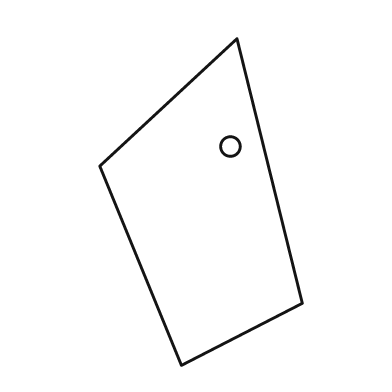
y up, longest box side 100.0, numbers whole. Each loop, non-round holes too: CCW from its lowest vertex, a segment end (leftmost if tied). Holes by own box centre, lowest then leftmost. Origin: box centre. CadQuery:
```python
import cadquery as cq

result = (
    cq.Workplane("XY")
    .moveTo(-6.0, -50.0)
    .lineTo(31.0, -31.0)
    .lineTo(11.0, 50.0)
    .lineTo(-31.0, 11.0)
    .close()
    .moveTo(9.0, 17.0)
    .circle(3.0)
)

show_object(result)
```